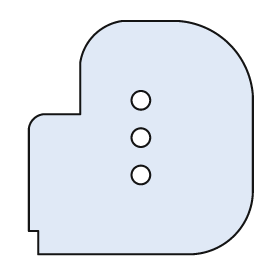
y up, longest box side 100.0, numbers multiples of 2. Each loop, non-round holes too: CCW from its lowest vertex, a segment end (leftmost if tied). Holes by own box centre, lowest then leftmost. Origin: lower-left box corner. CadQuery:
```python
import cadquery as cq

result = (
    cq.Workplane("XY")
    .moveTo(4.0, 0.0)
    .lineTo(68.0, 0.0)
    .threePointArc((88.0, 8.0), (96.0, 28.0))
    .lineTo(96.0, 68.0)
    .threePointArc((86.0, 90.0), (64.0, 100.0))
    .lineTo(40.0, 100.0)
    .threePointArc((28.0, 94.0), (22.0, 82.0))
    .lineTo(22.0, 60.0)
    .lineTo(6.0, 60.0)
    .threePointArc((2.0, 58.0), (0.0, 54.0))
    .lineTo(0.0, 10.0)
    .lineTo(4.0, 10.0)
    .close()
    .moveTo(48.0, 34.0)
    .circle(4.0)
    .moveTo(48.0, 50.0)
    .circle(4.0)
    .moveTo(48.0, 66.0)
    .circle(4.0)
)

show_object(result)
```